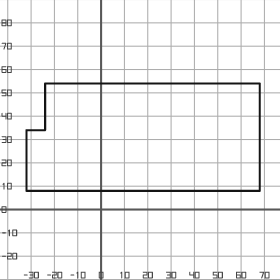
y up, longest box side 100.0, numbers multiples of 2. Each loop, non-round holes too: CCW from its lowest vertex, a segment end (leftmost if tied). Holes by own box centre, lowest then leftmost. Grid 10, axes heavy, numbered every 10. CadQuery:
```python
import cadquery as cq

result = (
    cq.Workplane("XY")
    .moveTo(-32.0, 8.0)
    .lineTo(68.0, 8.0)
    .lineTo(68.0, 54.0)
    .lineTo(-24.0, 54.0)
    .lineTo(-24.0, 34.0)
    .lineTo(-32.0, 34.0)
    .close()
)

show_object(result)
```